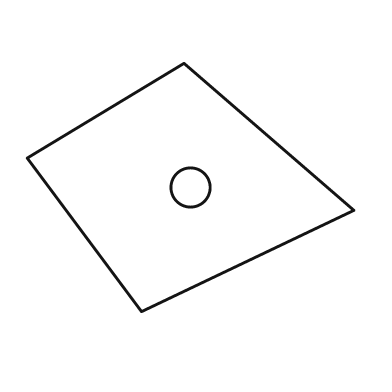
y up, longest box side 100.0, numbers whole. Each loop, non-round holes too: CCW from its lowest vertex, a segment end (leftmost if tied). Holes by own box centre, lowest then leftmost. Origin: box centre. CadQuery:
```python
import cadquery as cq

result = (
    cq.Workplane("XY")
    .moveTo(-15.0, -38.0)
    .lineTo(50.0, -7.0)
    .lineTo(-2.0, 38.0)
    .lineTo(-50.0, 9.0)
    .close()
    .moveTo(0.0, 0.0)
    .circle(6.0)
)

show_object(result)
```